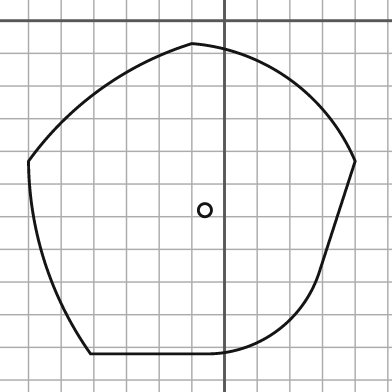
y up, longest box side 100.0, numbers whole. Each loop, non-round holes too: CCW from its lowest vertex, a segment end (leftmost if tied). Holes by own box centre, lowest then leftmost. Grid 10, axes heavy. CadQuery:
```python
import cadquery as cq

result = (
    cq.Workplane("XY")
    .moveTo(-41.0, -102.0)
    .lineTo(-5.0, -102.0)
    .threePointArc((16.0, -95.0), (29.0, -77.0))
    .lineTo(40.0, -43.0)
    .threePointArc((20.0, -18.0), (-10.0, -7.0))
    .threePointArc((-38.0, -21.0), (-60.0, -43.0))
    .threePointArc((-55.0, -74.0), (-41.0, -102.0))
    .close()
    .moveTo(-6.0, -58.0)
    .circle(2.0)
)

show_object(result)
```